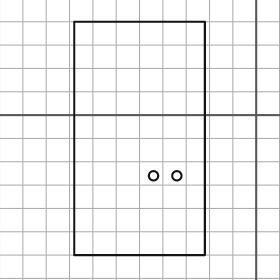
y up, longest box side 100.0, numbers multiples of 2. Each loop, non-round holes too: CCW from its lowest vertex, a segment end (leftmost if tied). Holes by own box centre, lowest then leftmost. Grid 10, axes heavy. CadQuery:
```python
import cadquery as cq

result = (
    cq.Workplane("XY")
    .moveTo(-78.0, -60.0)
    .lineTo(-22.0, -60.0)
    .lineTo(-22.0, 40.0)
    .lineTo(-78.0, 40.0)
    .close()
    .moveTo(-44.0, -26.0)
    .circle(2.0)
    .moveTo(-34.0, -26.0)
    .circle(2.0)
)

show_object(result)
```